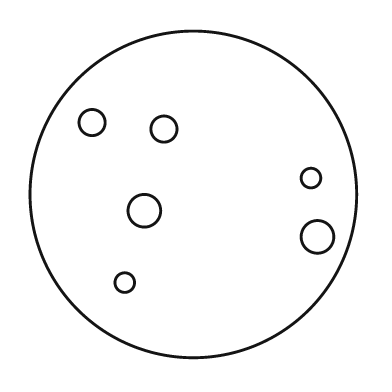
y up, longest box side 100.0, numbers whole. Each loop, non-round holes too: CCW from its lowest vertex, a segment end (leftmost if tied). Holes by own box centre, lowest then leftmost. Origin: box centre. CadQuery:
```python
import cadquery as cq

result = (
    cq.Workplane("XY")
    .moveTo(0.0, 0.0)
    .circle(50.0)
    .moveTo(-21.0, -27.0)
    .circle(3.0)
    .moveTo(38.0, -13.0)
    .circle(5.0)
    .moveTo(-15.0, -5.0)
    .circle(5.0)
    .moveTo(36.0, 5.0)
    .circle(3.0)
    .moveTo(-9.0, 20.0)
    .circle(4.0)
    .moveTo(-31.0, 22.0)
    .circle(4.0)
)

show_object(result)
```